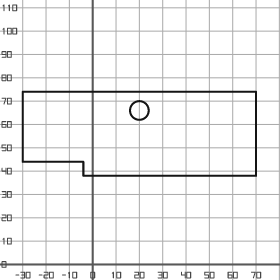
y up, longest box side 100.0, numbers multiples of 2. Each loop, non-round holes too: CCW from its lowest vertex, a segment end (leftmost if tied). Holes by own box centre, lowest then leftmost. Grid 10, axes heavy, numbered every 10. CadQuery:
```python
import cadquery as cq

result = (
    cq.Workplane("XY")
    .moveTo(-4.0, 38.0)
    .lineTo(70.0, 38.0)
    .lineTo(70.0, 74.0)
    .lineTo(-30.0, 74.0)
    .lineTo(-30.0, 44.0)
    .lineTo(-4.0, 44.0)
    .close()
    .moveTo(20.0, 66.0)
    .circle(4.0)
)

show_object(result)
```